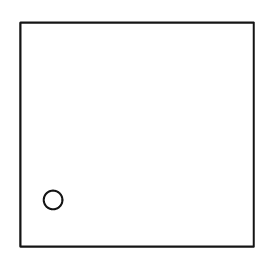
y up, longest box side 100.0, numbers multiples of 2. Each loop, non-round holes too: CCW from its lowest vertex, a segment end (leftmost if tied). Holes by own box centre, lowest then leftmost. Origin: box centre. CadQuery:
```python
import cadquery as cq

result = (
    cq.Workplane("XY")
    .moveTo(-50.0, -48.0)
    .lineTo(50.0, -48.0)
    .lineTo(50.0, 48.0)
    .lineTo(-50.0, 48.0)
    .close()
    .moveTo(-36.0, -28.0)
    .circle(4.0)
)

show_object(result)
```